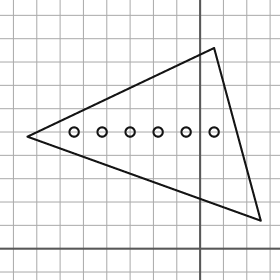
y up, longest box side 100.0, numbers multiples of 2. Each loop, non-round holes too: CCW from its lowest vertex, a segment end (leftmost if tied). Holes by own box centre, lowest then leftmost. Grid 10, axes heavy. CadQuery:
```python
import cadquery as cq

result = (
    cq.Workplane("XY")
    .moveTo(26.0, 12.0)
    .lineTo(6.0, 86.0)
    .lineTo(-74.0, 48.0)
    .close()
    .moveTo(-54.0, 50.0)
    .circle(2.0)
    .moveTo(-42.0, 50.0)
    .circle(2.0)
    .moveTo(-30.0, 50.0)
    .circle(2.0)
    .moveTo(-18.0, 50.0)
    .circle(2.0)
    .moveTo(-6.0, 50.0)
    .circle(2.0)
    .moveTo(6.0, 50.0)
    .circle(2.0)
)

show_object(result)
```